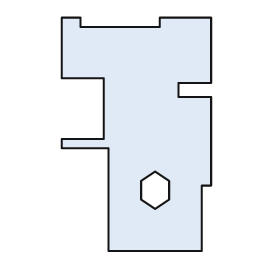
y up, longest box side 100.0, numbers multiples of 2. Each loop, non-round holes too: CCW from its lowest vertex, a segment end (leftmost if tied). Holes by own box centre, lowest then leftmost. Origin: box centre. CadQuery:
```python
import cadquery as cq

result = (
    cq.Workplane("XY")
    .moveTo(-12.0, -50.0)
    .lineTo(28.0, -50.0)
    .lineTo(28.0, -22.0)
    .lineTo(32.0, -22.0)
    .lineTo(32.0, 16.0)
    .lineTo(18.0, 16.0)
    .lineTo(18.0, 22.0)
    .lineTo(32.0, 22.0)
    .lineTo(32.0, 50.0)
    .lineTo(10.0, 50.0)
    .lineTo(10.0, 46.0)
    .lineTo(-24.0, 46.0)
    .lineTo(-24.0, 50.0)
    .lineTo(-32.0, 50.0)
    .lineTo(-32.0, 24.0)
    .lineTo(-14.0, 24.0)
    .lineTo(-14.0, -2.0)
    .lineTo(-32.0, -2.0)
    .lineTo(-32.0, -6.0)
    .lineTo(-12.0, -6.0)
    .close()
    .moveTo(8.0, -32.0)
    .lineTo(14.0, -28.0)
    .lineTo(14.0, -20.0)
    .lineTo(8.0, -16.0)
    .lineTo(2.0, -20.0)
    .lineTo(2.0, -28.0)
    .close()
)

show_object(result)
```